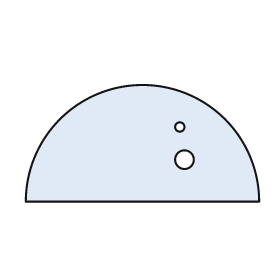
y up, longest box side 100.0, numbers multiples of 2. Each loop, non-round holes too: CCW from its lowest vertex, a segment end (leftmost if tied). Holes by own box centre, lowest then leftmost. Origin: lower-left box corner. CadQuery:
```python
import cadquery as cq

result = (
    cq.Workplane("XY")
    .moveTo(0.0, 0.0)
    .lineTo(100.0, 0.0)
    .threePointArc((50.0, 50.0), (0.0, 0.0))
    .close()
    .moveTo(68.0, 18.0)
    .circle(4.0)
    .moveTo(66.0, 32.0)
    .circle(2.0)
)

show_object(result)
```